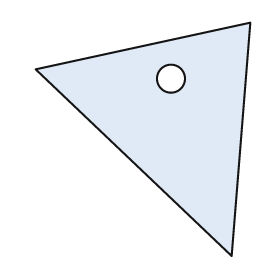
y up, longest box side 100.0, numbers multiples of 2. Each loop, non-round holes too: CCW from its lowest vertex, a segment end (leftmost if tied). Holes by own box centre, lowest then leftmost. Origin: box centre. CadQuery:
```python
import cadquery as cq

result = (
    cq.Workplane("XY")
    .moveTo(38.0, -50.0)
    .lineTo(46.0, 50.0)
    .lineTo(-46.0, 30.0)
    .close()
    .moveTo(12.0, 26.0)
    .circle(6.0)
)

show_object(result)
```